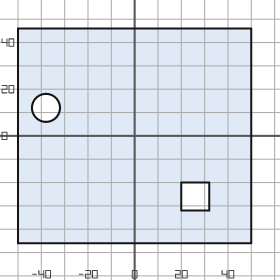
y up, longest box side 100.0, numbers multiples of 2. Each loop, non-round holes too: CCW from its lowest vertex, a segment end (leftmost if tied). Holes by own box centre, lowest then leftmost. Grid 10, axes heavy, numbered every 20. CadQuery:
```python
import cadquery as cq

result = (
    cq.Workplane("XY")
    .moveTo(-50.0, -46.0)
    .lineTo(50.0, -46.0)
    .lineTo(50.0, 46.0)
    .lineTo(-50.0, 46.0)
    .close()
    .moveTo(20.0, -32.0)
    .lineTo(32.0, -32.0)
    .lineTo(32.0, -20.0)
    .lineTo(20.0, -20.0)
    .close()
    .moveTo(-38.0, 12.0)
    .circle(6.0)
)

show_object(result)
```